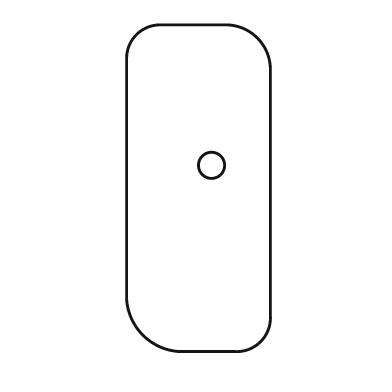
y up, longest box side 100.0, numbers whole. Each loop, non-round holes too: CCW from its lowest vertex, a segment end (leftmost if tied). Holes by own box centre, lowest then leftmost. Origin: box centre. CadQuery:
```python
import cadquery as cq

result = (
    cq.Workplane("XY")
    .moveTo(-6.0, -50.0)
    .lineTo(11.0, -50.0)
    .threePointArc((19.0, -47.0), (22.0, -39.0))
    .lineTo(22.0, 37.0)
    .threePointArc((18.0, 46.0), (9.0, 50.0))
    .lineTo(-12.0, 50.0)
    .threePointArc((-19.0, 47.0), (-22.0, 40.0))
    .lineTo(-22.0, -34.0)
    .threePointArc((-17.0, -45.0), (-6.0, -50.0))
    .close()
    .moveTo(4.0, 7.0)
    .circle(4.0)
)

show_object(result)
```